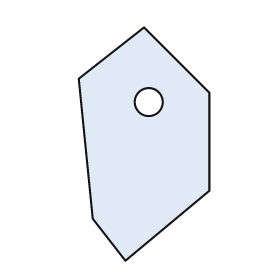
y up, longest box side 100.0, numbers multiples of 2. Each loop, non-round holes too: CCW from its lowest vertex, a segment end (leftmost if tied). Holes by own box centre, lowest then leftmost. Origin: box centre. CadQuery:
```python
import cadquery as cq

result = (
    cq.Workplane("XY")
    .moveTo(-8.0, -50.0)
    .lineTo(28.0, -20.0)
    .lineTo(28.0, 22.0)
    .lineTo(0.0, 50.0)
    .lineTo(-28.0, 28.0)
    .lineTo(-22.0, -32.0)
    .close()
    .moveTo(2.0, 18.0)
    .circle(6.0)
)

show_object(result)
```